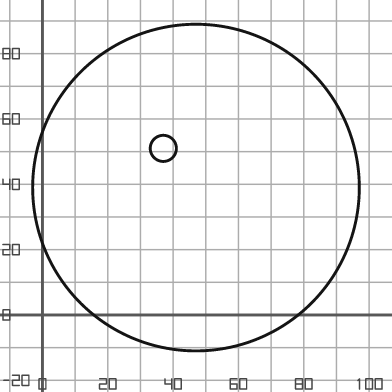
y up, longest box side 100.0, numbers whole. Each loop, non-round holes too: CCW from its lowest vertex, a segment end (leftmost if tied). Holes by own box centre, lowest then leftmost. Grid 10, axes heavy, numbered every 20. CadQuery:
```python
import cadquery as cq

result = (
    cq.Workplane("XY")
    .moveTo(47.0, 39.0)
    .circle(50.0)
    .moveTo(37.0, 51.0)
    .circle(4.0)
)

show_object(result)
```